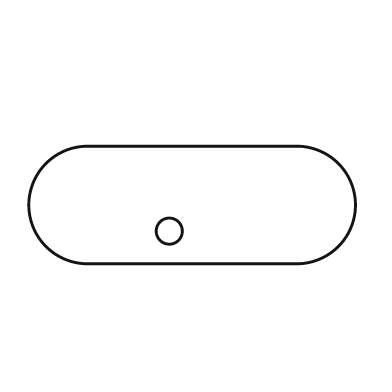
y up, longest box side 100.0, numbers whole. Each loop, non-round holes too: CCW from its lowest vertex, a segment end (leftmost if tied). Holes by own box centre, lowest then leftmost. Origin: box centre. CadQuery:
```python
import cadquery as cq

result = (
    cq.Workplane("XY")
    .moveTo(-32.0, -18.0)
    .lineTo(32.0, -18.0)
    .threePointArc((50.0, 0.0), (32.0, 18.0))
    .lineTo(-32.0, 18.0)
    .threePointArc((-50.0, 0.0), (-32.0, -18.0))
    .close()
    .moveTo(-7.0, -8.0)
    .circle(4.0)
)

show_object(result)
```